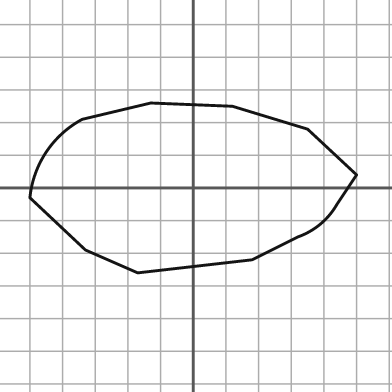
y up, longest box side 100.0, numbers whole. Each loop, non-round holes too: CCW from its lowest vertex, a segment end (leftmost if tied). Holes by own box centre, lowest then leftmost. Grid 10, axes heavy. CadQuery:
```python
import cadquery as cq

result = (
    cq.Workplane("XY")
    .moveTo(-17.0, -26.0)
    .lineTo(18.0, -22.0)
    .lineTo(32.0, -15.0)
    .threePointArc((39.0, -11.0), (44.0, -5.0))
    .lineTo(50.0, 4.0)
    .lineTo(35.0, 18.0)
    .lineTo(12.0, 25.0)
    .lineTo(-13.0, 26.0)
    .lineTo(-34.0, 21.0)
    .threePointArc((-45.0, 11.0), (-50.0, -3.0))
    .lineTo(-33.0, -19.0)
    .close()
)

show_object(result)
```